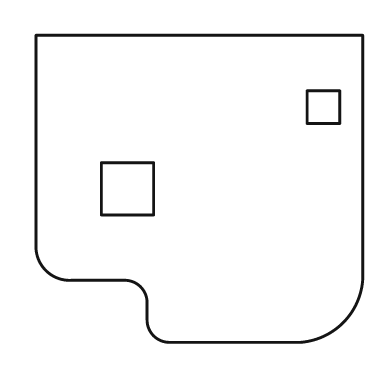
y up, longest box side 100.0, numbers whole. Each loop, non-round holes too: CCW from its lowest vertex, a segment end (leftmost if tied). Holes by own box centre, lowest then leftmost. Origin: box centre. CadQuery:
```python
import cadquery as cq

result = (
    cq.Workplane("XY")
    .moveTo(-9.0, -47.0)
    .lineTo(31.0, -47.0)
    .threePointArc((44.0, -41.0), (50.0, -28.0))
    .lineTo(50.0, 47.0)
    .lineTo(-50.0, 47.0)
    .lineTo(-50.0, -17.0)
    .threePointArc((-47.0, -25.0), (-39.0, -28.0))
    .lineTo(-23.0, -28.0)
    .threePointArc((-18.0, -30.0), (-16.0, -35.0))
    .lineTo(-16.0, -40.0)
    .threePointArc((-14.0, -45.0), (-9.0, -47.0))
    .close()
    .moveTo(-30.0, -8.0)
    .lineTo(-14.0, -8.0)
    .lineTo(-14.0, 8.0)
    .lineTo(-30.0, 8.0)
    .close()
    .moveTo(33.0, 20.0)
    .lineTo(43.0, 20.0)
    .lineTo(43.0, 30.0)
    .lineTo(33.0, 30.0)
    .close()
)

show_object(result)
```